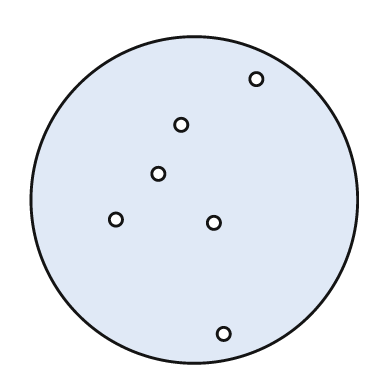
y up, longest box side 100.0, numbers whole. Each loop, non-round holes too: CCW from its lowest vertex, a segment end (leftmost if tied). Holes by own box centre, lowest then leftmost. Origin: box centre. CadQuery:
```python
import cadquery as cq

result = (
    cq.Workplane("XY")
    .moveTo(0.0, 0.0)
    .circle(50.0)
    .moveTo(9.0, -41.0)
    .circle(2.0)
    .moveTo(6.0, -7.0)
    .circle(2.0)
    .moveTo(-24.0, -6.0)
    .circle(2.0)
    .moveTo(-11.0, 8.0)
    .circle(2.0)
    .moveTo(-4.0, 23.0)
    .circle(2.0)
    .moveTo(19.0, 37.0)
    .circle(2.0)
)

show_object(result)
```